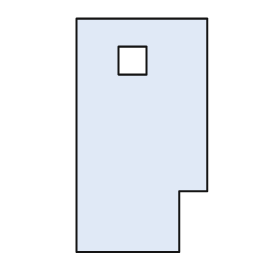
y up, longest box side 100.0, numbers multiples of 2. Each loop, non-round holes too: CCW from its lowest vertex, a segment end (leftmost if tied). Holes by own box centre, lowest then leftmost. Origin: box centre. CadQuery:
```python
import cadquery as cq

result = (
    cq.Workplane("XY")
    .moveTo(-28.0, -50.0)
    .lineTo(16.0, -50.0)
    .lineTo(16.0, -24.0)
    .lineTo(28.0, -24.0)
    .lineTo(28.0, 50.0)
    .lineTo(-28.0, 50.0)
    .close()
    .moveTo(-10.0, 26.0)
    .lineTo(2.0, 26.0)
    .lineTo(2.0, 38.0)
    .lineTo(-10.0, 38.0)
    .close()
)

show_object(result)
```